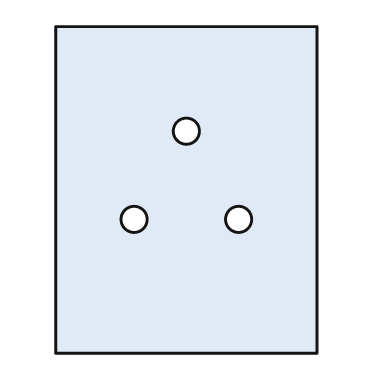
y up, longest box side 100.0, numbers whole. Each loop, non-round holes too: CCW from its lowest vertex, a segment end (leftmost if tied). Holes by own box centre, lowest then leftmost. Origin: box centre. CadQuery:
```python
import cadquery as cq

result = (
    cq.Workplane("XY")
    .moveTo(-40.0, -50.0)
    .lineTo(40.0, -50.0)
    .lineTo(40.0, 50.0)
    .lineTo(-40.0, 50.0)
    .close()
    .moveTo(-16.0, -9.0)
    .circle(4.0)
    .moveTo(16.0, -9.0)
    .circle(4.0)
    .moveTo(0.0, 18.0)
    .circle(4.0)
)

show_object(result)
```